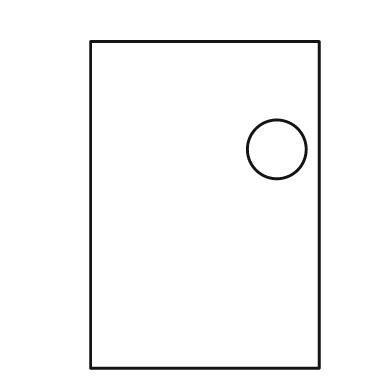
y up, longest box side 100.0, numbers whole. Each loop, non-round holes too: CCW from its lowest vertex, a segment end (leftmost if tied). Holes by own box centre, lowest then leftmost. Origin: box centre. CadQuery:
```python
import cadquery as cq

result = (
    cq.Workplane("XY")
    .moveTo(-35.0, -50.0)
    .lineTo(35.0, -50.0)
    .lineTo(35.0, 50.0)
    .lineTo(-35.0, 50.0)
    .close()
    .moveTo(22.0, 17.0)
    .circle(9.0)
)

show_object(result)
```